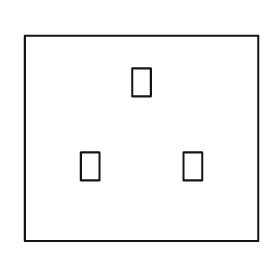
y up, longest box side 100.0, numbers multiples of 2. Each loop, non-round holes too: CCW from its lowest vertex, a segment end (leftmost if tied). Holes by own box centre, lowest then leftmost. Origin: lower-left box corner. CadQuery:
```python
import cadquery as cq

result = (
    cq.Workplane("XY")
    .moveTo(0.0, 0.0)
    .lineTo(100.0, 0.0)
    .lineTo(100.0, 88.0)
    .lineTo(0.0, 88.0)
    .close()
    .moveTo(24.0, 26.0)
    .lineTo(32.0, 26.0)
    .lineTo(32.0, 38.0)
    .lineTo(24.0, 38.0)
    .close()
    .moveTo(68.0, 26.0)
    .lineTo(76.0, 26.0)
    .lineTo(76.0, 38.0)
    .lineTo(68.0, 38.0)
    .close()
    .moveTo(46.0, 62.0)
    .lineTo(54.0, 62.0)
    .lineTo(54.0, 74.0)
    .lineTo(46.0, 74.0)
    .close()
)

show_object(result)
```